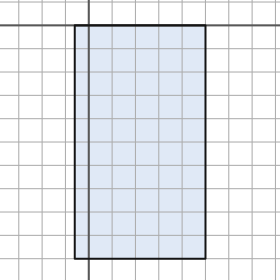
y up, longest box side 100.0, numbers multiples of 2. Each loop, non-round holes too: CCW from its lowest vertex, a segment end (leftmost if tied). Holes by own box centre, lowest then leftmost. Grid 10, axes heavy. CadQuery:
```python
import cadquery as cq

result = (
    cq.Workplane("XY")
    .moveTo(-6.0, -100.0)
    .lineTo(50.0, -100.0)
    .lineTo(50.0, 0.0)
    .lineTo(-6.0, 0.0)
    .close()
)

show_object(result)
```